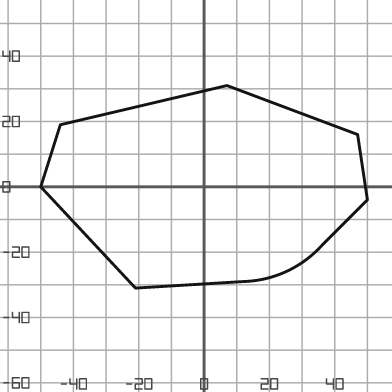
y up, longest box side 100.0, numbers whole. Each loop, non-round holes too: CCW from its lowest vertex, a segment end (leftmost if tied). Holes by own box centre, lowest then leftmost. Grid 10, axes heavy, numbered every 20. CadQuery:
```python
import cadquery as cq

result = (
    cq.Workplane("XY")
    .moveTo(-21.0, -31.0)
    .lineTo(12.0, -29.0)
    .threePointArc((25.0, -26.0), (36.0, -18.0))
    .lineTo(50.0, -4.0)
    .lineTo(47.0, 16.0)
    .lineTo(7.0, 31.0)
    .lineTo(-44.0, 19.0)
    .lineTo(-50.0, 0.0)
    .close()
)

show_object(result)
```